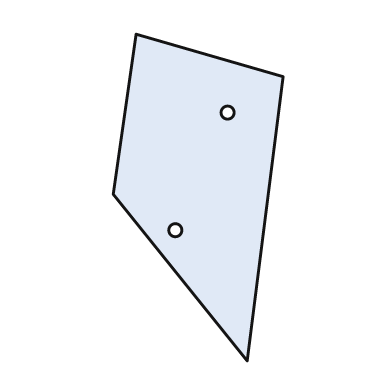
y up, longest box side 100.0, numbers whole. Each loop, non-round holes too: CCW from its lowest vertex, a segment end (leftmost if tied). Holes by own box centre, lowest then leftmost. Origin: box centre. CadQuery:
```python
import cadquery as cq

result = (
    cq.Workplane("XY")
    .moveTo(15.0, -50.0)
    .lineTo(26.0, 37.0)
    .lineTo(-19.0, 50.0)
    .lineTo(-26.0, 1.0)
    .close()
    .moveTo(-7.0, -10.0)
    .circle(2.0)
    .moveTo(9.0, 26.0)
    .circle(2.0)
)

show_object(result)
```